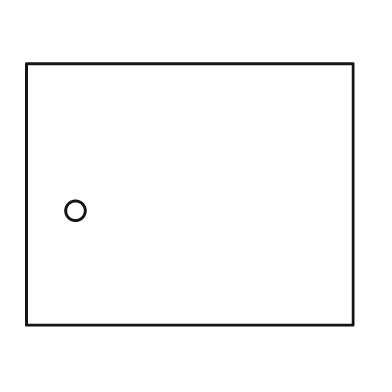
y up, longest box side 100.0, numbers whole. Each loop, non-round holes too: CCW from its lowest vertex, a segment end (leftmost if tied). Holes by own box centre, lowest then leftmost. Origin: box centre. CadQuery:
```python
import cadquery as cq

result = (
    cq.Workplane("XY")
    .moveTo(-50.0, -40.0)
    .lineTo(50.0, -40.0)
    .lineTo(50.0, 40.0)
    .lineTo(-50.0, 40.0)
    .close()
    .moveTo(-35.0, -5.0)
    .circle(3.0)
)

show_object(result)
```